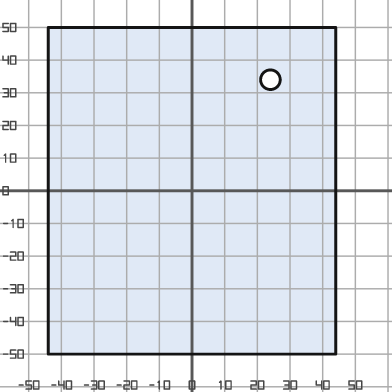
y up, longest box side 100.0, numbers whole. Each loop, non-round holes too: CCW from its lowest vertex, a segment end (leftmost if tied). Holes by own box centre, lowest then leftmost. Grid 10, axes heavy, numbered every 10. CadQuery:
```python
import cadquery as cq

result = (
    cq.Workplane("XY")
    .moveTo(-44.0, -50.0)
    .lineTo(44.0, -50.0)
    .lineTo(44.0, 50.0)
    .lineTo(-44.0, 50.0)
    .close()
    .moveTo(24.0, 34.0)
    .circle(3.0)
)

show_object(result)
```